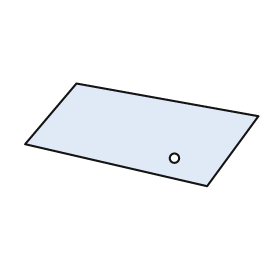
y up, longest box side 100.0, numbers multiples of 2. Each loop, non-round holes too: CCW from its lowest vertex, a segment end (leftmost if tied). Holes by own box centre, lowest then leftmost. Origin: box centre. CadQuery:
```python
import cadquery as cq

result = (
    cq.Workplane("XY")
    .moveTo(28.0, -22.0)
    .lineTo(50.0, 8.0)
    .lineTo(-28.0, 22.0)
    .lineTo(-50.0, -4.0)
    .close()
    .moveTo(14.0, -10.0)
    .circle(2.0)
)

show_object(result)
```